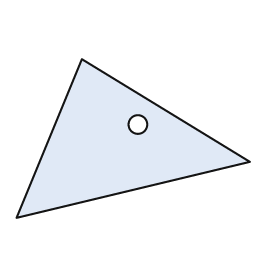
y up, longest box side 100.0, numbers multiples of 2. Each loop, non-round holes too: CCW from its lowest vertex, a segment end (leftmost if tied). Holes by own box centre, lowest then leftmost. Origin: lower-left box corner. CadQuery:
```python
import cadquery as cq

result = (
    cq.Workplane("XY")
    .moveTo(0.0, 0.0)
    .lineTo(100.0, 24.0)
    .lineTo(28.0, 68.0)
    .close()
    .moveTo(52.0, 40.0)
    .circle(4.0)
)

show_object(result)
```